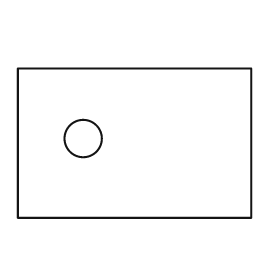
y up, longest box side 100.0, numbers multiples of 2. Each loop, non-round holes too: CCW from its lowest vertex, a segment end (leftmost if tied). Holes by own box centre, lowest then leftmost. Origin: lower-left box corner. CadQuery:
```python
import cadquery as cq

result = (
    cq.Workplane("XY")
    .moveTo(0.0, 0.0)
    .lineTo(100.0, 0.0)
    .lineTo(100.0, 64.0)
    .lineTo(0.0, 64.0)
    .close()
    .moveTo(28.0, 34.0)
    .circle(8.0)
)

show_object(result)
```